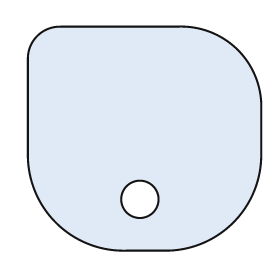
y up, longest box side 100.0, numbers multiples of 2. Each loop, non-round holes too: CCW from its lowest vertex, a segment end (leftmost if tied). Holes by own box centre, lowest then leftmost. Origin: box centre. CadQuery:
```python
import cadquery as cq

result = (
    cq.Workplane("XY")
    .moveTo(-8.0, -48.0)
    .lineTo(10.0, -48.0)
    .threePointArc((38.0, -36.0), (50.0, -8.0))
    .lineTo(50.0, 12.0)
    .threePointArc((40.0, 38.0), (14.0, 48.0))
    .lineTo(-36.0, 48.0)
    .threePointArc((-46.0, 44.0), (-50.0, 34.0))
    .lineTo(-50.0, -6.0)
    .threePointArc((-38.0, -36.0), (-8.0, -48.0))
    .close()
    .moveTo(-2.0, -26.0)
    .circle(8.0)
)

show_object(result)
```